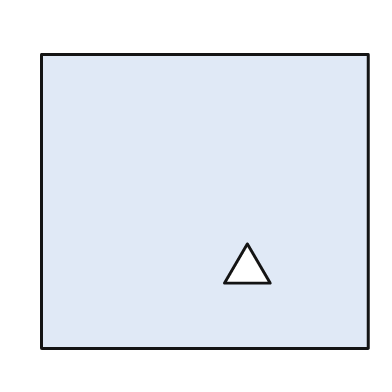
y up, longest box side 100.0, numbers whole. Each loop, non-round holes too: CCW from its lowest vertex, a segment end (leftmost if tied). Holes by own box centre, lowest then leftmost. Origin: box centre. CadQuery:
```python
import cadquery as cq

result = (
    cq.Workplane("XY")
    .moveTo(-50.0, -45.0)
    .lineTo(50.0, -45.0)
    .lineTo(50.0, 45.0)
    .lineTo(-50.0, 45.0)
    .close()
    .moveTo(6.0, -25.0)
    .lineTo(20.0, -25.0)
    .lineTo(13.0, -13.0)
    .close()
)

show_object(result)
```